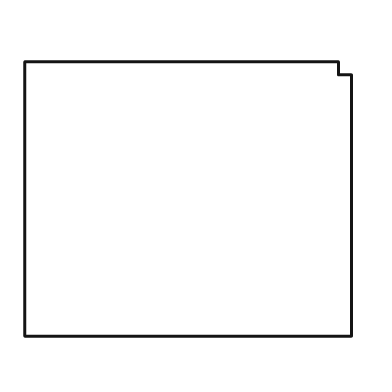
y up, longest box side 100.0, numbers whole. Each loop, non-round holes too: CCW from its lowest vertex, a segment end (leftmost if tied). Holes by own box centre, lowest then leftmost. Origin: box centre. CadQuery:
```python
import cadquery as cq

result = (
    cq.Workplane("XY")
    .moveTo(-50.0, -42.0)
    .lineTo(50.0, -42.0)
    .lineTo(50.0, 38.0)
    .lineTo(46.0, 38.0)
    .lineTo(46.0, 42.0)
    .lineTo(-50.0, 42.0)
    .close()
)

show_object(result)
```